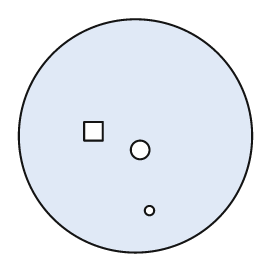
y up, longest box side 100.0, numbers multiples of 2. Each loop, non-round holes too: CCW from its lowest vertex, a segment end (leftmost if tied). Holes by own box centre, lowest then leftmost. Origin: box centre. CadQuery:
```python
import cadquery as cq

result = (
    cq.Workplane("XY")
    .moveTo(0.0, 0.0)
    .circle(50.0)
    .moveTo(6.0, -32.0)
    .circle(2.0)
    .moveTo(2.0, -6.0)
    .circle(4.0)
    .moveTo(-22.0, -2.0)
    .lineTo(-14.0, -2.0)
    .lineTo(-14.0, 6.0)
    .lineTo(-22.0, 6.0)
    .close()
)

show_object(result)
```